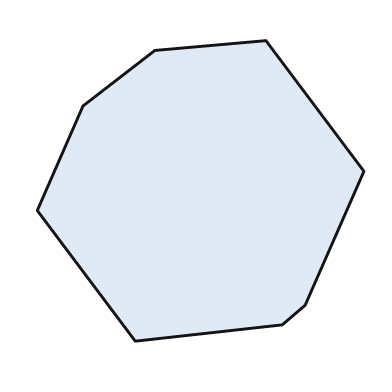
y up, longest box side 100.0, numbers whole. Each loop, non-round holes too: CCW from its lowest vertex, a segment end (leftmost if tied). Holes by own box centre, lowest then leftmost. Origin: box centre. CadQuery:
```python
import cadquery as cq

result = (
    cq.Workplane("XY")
    .moveTo(-20.0, -46.0)
    .lineTo(25.0, -41.0)
    .lineTo(32.0, -35.0)
    .lineTo(50.0, 6.0)
    .lineTo(20.0, 46.0)
    .lineTo(-14.0, 43.0)
    .lineTo(-36.0, 26.0)
    .lineTo(-50.0, -6.0)
    .close()
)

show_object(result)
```